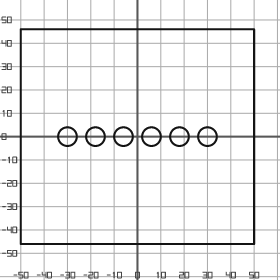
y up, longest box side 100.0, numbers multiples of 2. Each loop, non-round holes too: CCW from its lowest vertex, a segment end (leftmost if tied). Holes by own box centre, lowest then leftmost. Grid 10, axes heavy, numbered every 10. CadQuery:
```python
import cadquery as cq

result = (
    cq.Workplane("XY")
    .moveTo(-50.0, -46.0)
    .lineTo(50.0, -46.0)
    .lineTo(50.0, 46.0)
    .lineTo(-50.0, 46.0)
    .close()
    .moveTo(-30.0, 0.0)
    .circle(4.0)
    .moveTo(-18.0, 0.0)
    .circle(4.0)
    .moveTo(-6.0, 0.0)
    .circle(4.0)
    .moveTo(6.0, 0.0)
    .circle(4.0)
    .moveTo(18.0, 0.0)
    .circle(4.0)
    .moveTo(30.0, 0.0)
    .circle(4.0)
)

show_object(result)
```